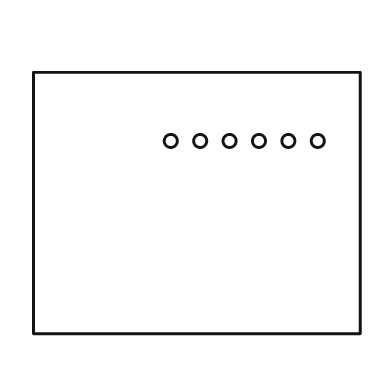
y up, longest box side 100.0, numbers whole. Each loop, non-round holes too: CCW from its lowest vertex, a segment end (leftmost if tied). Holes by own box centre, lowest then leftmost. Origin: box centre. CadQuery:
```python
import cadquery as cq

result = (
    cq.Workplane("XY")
    .moveTo(-50.0, -40.0)
    .lineTo(50.0, -40.0)
    .lineTo(50.0, 40.0)
    .lineTo(-50.0, 40.0)
    .close()
    .moveTo(-8.0, 19.0)
    .circle(2.0)
    .moveTo(1.0, 19.0)
    .circle(2.0)
    .moveTo(10.0, 19.0)
    .circle(2.0)
    .moveTo(19.0, 19.0)
    .circle(2.0)
    .moveTo(28.0, 19.0)
    .circle(2.0)
    .moveTo(37.0, 19.0)
    .circle(2.0)
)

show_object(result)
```